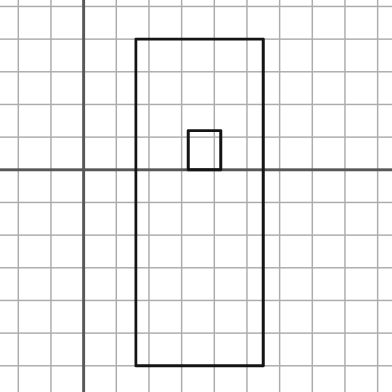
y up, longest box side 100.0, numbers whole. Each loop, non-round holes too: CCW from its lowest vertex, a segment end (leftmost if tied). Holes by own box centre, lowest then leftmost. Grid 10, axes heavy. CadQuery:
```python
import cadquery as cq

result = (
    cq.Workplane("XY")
    .moveTo(16.0, -60.0)
    .lineTo(55.0, -60.0)
    .lineTo(55.0, 40.0)
    .lineTo(16.0, 40.0)
    .close()
    .moveTo(32.0, 0.0)
    .lineTo(42.0, 0.0)
    .lineTo(42.0, 12.0)
    .lineTo(32.0, 12.0)
    .close()
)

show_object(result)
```